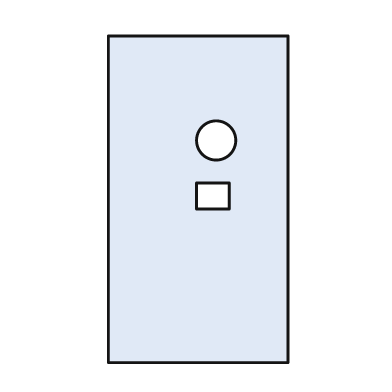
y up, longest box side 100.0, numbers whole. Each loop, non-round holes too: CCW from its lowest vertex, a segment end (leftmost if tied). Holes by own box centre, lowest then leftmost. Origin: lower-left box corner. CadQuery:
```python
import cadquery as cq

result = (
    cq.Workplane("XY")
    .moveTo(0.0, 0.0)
    .lineTo(55.0, 0.0)
    .lineTo(55.0, 100.0)
    .lineTo(0.0, 100.0)
    .close()
    .moveTo(27.0, 47.0)
    .lineTo(37.0, 47.0)
    .lineTo(37.0, 55.0)
    .lineTo(27.0, 55.0)
    .close()
    .moveTo(33.0, 68.0)
    .circle(6.0)
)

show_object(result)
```